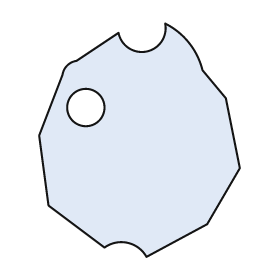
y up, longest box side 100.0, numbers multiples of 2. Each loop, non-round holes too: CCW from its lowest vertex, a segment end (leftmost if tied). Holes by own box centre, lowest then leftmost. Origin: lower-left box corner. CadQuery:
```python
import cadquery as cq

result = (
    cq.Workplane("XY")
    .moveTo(46.0, 0.0)
    .lineTo(72.0, 14.0)
    .lineTo(86.0, 38.0)
    .lineTo(80.0, 68.0)
    .lineTo(70.0, 80.0)
    .threePointArc((64.0, 92.0), (54.0, 100.0))
    .threePointArc((46.0, 88.0), (34.0, 96.0))
    .lineTo(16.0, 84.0)
    .threePointArc((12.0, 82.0), (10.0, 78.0))
    .lineTo(0.0, 52.0)
    .lineTo(4.0, 22.0)
    .lineTo(28.0, 4.0)
    .threePointArc((38.0, 6.0), (46.0, 0.0))
    .close()
    .moveTo(20.0, 64.0)
    .circle(8.0)
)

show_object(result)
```